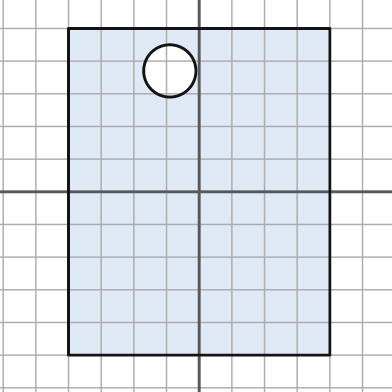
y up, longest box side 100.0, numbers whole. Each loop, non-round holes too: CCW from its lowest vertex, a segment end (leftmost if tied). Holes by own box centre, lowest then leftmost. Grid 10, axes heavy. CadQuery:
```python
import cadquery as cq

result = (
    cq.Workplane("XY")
    .moveTo(-40.0, -50.0)
    .lineTo(40.0, -50.0)
    .lineTo(40.0, 50.0)
    .lineTo(-40.0, 50.0)
    .close()
    .moveTo(-9.0, 37.0)
    .circle(8.0)
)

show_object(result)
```